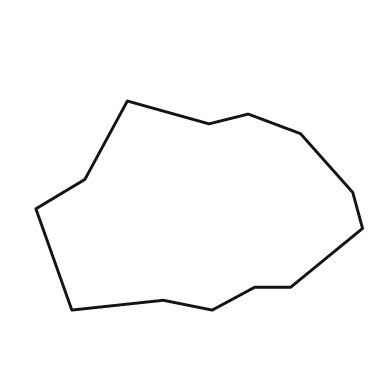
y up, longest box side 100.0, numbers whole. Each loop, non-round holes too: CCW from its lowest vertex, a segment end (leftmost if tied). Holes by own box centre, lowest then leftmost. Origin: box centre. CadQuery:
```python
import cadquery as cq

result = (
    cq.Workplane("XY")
    .moveTo(-39.0, -32.0)
    .lineTo(-11.0, -29.0)
    .lineTo(4.0, -32.0)
    .lineTo(17.0, -25.0)
    .lineTo(28.0, -25.0)
    .lineTo(50.0, -7.0)
    .lineTo(47.0, 4.0)
    .lineTo(31.0, 22.0)
    .lineTo(15.0, 28.0)
    .lineTo(3.0, 25.0)
    .lineTo(-22.0, 32.0)
    .lineTo(-35.0, 8.0)
    .lineTo(-50.0, -1.0)
    .close()
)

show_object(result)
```